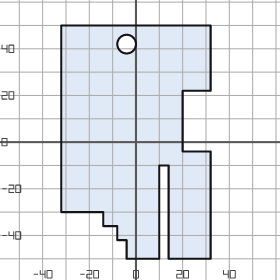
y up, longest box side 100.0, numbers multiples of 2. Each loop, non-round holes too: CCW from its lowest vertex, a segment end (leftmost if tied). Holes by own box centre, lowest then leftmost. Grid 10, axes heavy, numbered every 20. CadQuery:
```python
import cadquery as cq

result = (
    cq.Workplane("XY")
    .moveTo(-4.0, -50.0)
    .lineTo(10.0, -50.0)
    .lineTo(10.0, -10.0)
    .lineTo(14.0, -10.0)
    .lineTo(14.0, -50.0)
    .lineTo(32.0, -50.0)
    .lineTo(32.0, -4.0)
    .lineTo(20.0, -4.0)
    .lineTo(20.0, 22.0)
    .lineTo(32.0, 22.0)
    .lineTo(32.0, 50.0)
    .lineTo(-32.0, 50.0)
    .lineTo(-32.0, -30.0)
    .lineTo(-14.0, -30.0)
    .lineTo(-14.0, -36.0)
    .lineTo(-8.0, -36.0)
    .lineTo(-8.0, -42.0)
    .lineTo(-4.0, -42.0)
    .close()
    .moveTo(-4.0, 42.0)
    .circle(4.0)
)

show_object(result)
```